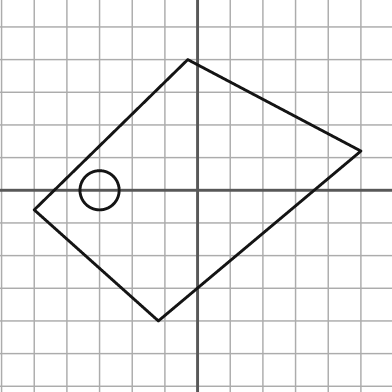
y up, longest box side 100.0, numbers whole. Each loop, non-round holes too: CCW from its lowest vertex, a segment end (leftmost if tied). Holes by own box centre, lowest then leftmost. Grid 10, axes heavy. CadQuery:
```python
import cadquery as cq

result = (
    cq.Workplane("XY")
    .moveTo(-12.0, -40.0)
    .lineTo(50.0, 12.0)
    .lineTo(-3.0, 40.0)
    .lineTo(-50.0, -6.0)
    .close()
    .moveTo(-30.0, 0.0)
    .circle(6.0)
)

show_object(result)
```